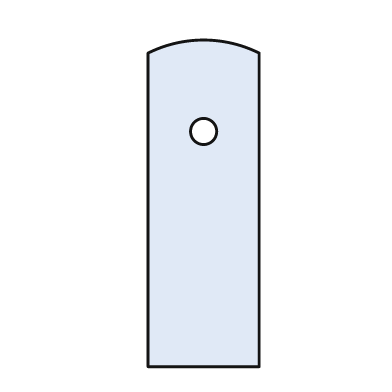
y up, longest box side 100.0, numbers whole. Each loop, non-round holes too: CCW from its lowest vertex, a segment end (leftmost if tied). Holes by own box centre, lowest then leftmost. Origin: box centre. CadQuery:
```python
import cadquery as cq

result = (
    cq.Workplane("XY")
    .moveTo(-17.0, -50.0)
    .lineTo(17.0, -50.0)
    .lineTo(17.0, 46.0)
    .threePointArc((0.0, 50.0), (-17.0, 46.0))
    .close()
    .moveTo(0.0, 22.0)
    .circle(4.0)
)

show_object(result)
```